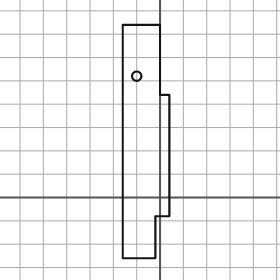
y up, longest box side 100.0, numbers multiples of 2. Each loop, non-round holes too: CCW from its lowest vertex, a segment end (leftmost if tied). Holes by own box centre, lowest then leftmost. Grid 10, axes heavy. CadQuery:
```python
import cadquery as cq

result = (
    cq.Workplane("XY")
    .moveTo(-16.0, -26.0)
    .lineTo(-2.0, -26.0)
    .lineTo(-2.0, -8.0)
    .lineTo(4.0, -8.0)
    .lineTo(4.0, 44.0)
    .lineTo(0.0, 44.0)
    .lineTo(0.0, 74.0)
    .lineTo(-16.0, 74.0)
    .close()
    .moveTo(-10.0, 52.0)
    .circle(2.0)
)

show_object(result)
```